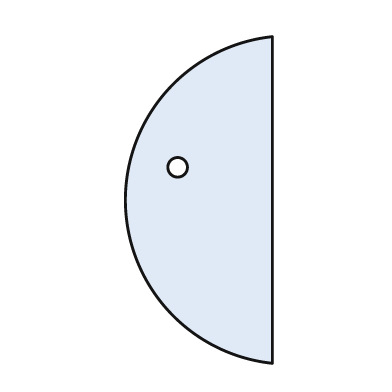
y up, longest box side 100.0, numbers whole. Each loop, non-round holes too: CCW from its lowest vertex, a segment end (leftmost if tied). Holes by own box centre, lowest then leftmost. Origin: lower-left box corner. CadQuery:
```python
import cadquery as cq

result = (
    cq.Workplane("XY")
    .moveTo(45.0, 0.0)
    .lineTo(45.0, 100.0)
    .threePointArc((0.0, 50.0), (45.0, 0.0))
    .close()
    .moveTo(16.0, 60.0)
    .circle(3.0)
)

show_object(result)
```